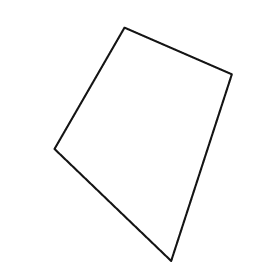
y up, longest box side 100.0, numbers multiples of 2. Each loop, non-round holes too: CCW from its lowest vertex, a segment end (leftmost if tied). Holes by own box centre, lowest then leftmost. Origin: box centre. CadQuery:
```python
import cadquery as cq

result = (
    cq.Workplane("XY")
    .moveTo(12.0, -50.0)
    .lineTo(38.0, 30.0)
    .lineTo(-8.0, 50.0)
    .lineTo(-38.0, -2.0)
    .close()
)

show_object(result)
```